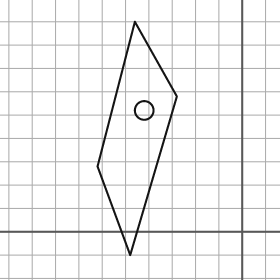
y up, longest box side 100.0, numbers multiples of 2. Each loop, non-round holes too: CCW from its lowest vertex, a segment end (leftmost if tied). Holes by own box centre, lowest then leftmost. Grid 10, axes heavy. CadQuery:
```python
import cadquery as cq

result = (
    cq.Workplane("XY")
    .moveTo(-48.0, -10.0)
    .lineTo(-28.0, 58.0)
    .lineTo(-46.0, 90.0)
    .lineTo(-62.0, 28.0)
    .close()
    .moveTo(-42.0, 52.0)
    .circle(4.0)
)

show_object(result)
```